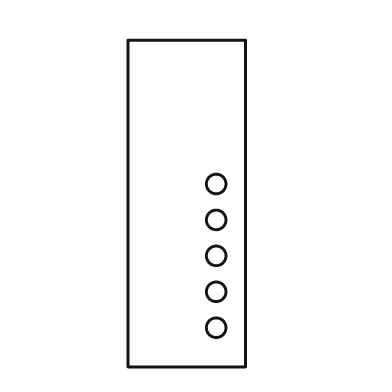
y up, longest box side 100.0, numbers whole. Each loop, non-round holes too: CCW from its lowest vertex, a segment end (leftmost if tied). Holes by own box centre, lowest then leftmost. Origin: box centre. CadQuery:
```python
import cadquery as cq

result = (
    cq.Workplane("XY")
    .moveTo(-18.0, -50.0)
    .lineTo(18.0, -50.0)
    .lineTo(18.0, 50.0)
    .lineTo(-18.0, 50.0)
    .close()
    .moveTo(9.0, -38.0)
    .circle(3.0)
    .moveTo(9.0, -27.0)
    .circle(3.0)
    .moveTo(9.0, -16.0)
    .circle(3.0)
    .moveTo(9.0, -5.0)
    .circle(3.0)
    .moveTo(9.0, 6.0)
    .circle(3.0)
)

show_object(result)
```